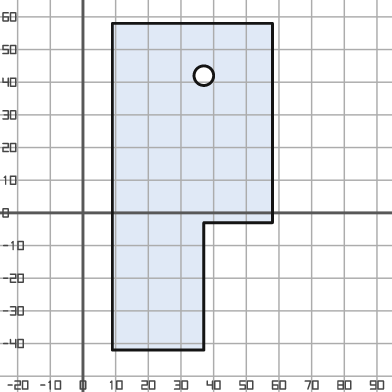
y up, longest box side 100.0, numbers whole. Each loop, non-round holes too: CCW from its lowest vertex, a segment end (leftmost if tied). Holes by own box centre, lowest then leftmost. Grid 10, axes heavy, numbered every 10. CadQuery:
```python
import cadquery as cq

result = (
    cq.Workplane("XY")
    .moveTo(9.0, -42.0)
    .lineTo(37.0, -42.0)
    .lineTo(37.0, -3.0)
    .lineTo(58.0, -3.0)
    .lineTo(58.0, 58.0)
    .lineTo(9.0, 58.0)
    .close()
    .moveTo(37.0, 42.0)
    .circle(3.0)
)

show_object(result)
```